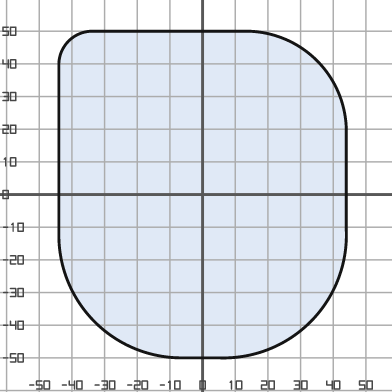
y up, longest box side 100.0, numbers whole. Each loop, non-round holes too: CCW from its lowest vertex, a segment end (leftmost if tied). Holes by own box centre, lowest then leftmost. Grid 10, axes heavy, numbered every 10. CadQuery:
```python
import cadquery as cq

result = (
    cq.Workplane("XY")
    .moveTo(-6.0, -50.0)
    .lineTo(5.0, -50.0)
    .threePointArc((33.0, -39.0), (44.0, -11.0))
    .lineTo(44.0, 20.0)
    .threePointArc((35.0, 41.0), (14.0, 50.0))
    .lineTo(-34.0, 50.0)
    .threePointArc((-41.0, 47.0), (-44.0, 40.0))
    .lineTo(-44.0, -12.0)
    .threePointArc((-33.0, -39.0), (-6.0, -50.0))
    .close()
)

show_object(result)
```